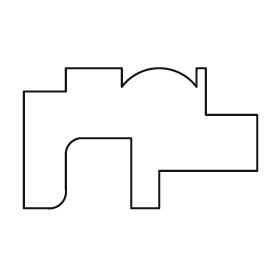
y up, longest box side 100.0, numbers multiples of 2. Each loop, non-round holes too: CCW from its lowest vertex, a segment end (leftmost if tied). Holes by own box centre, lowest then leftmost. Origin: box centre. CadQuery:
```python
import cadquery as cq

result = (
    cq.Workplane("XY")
    .moveTo(-50.0, -30.0)
    .lineTo(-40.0, -30.0)
    .threePointArc((-34.0, -28.0), (-32.0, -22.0))
    .lineTo(-32.0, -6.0)
    .threePointArc((-30.0, -2.0), (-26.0, 0.0))
    .lineTo(-4.0, 0.0)
    .lineTo(-4.0, -30.0)
    .lineTo(8.0, -30.0)
    .lineTo(8.0, -14.0)
    .lineTo(50.0, -14.0)
    .lineTo(50.0, 10.0)
    .lineTo(28.0, 10.0)
    .lineTo(28.0, 30.0)
    .lineTo(24.0, 30.0)
    .lineTo(24.0, 22.0)
    .threePointArc((8.0, 30.0), (-8.0, 22.0))
    .lineTo(-8.0, 30.0)
    .lineTo(-32.0, 30.0)
    .lineTo(-32.0, 20.0)
    .lineTo(-50.0, 20.0)
    .close()
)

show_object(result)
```